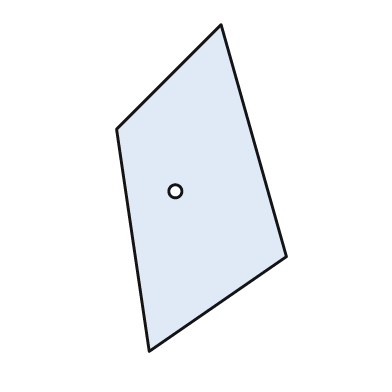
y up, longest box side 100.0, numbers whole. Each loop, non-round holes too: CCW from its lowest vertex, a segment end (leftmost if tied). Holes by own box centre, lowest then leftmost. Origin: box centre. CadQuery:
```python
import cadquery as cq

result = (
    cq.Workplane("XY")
    .moveTo(-16.0, -50.0)
    .lineTo(26.0, -21.0)
    .lineTo(6.0, 50.0)
    .lineTo(-26.0, 18.0)
    .close()
    .moveTo(-8.0, -1.0)
    .circle(2.0)
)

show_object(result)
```